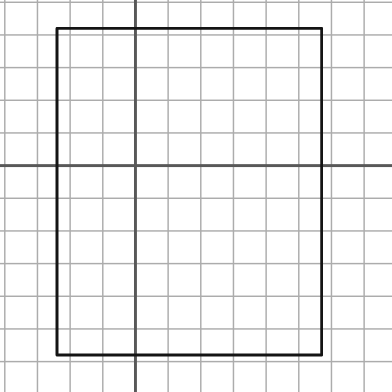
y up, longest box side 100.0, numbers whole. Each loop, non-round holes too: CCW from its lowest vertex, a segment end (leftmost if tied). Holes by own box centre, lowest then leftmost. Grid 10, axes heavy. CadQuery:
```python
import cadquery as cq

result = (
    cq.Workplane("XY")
    .moveTo(-24.0, -58.0)
    .lineTo(57.0, -58.0)
    .lineTo(57.0, 42.0)
    .lineTo(-24.0, 42.0)
    .close()
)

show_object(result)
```